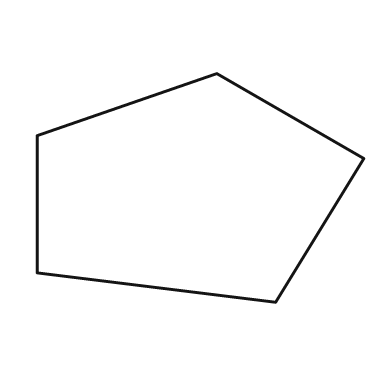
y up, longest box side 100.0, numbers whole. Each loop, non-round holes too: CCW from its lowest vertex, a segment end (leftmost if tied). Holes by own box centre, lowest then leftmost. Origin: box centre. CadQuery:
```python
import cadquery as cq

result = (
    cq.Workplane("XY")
    .moveTo(23.0, -35.0)
    .lineTo(50.0, 9.0)
    .lineTo(5.0, 35.0)
    .lineTo(-50.0, 16.0)
    .lineTo(-50.0, -26.0)
    .close()
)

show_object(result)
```